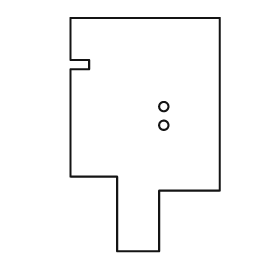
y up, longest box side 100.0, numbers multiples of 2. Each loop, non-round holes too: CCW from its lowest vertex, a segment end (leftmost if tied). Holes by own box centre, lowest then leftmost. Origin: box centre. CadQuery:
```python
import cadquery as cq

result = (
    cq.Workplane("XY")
    .moveTo(-12.0, -50.0)
    .lineTo(6.0, -50.0)
    .lineTo(6.0, -24.0)
    .lineTo(32.0, -24.0)
    .lineTo(32.0, 50.0)
    .lineTo(-32.0, 50.0)
    .lineTo(-32.0, 32.0)
    .lineTo(-24.0, 32.0)
    .lineTo(-24.0, 28.0)
    .lineTo(-32.0, 28.0)
    .lineTo(-32.0, -18.0)
    .lineTo(-12.0, -18.0)
    .close()
    .moveTo(8.0, 4.0)
    .circle(2.0)
    .moveTo(8.0, 12.0)
    .circle(2.0)
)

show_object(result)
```